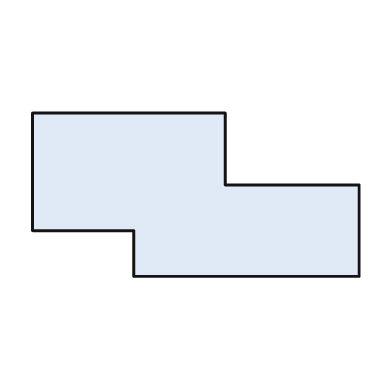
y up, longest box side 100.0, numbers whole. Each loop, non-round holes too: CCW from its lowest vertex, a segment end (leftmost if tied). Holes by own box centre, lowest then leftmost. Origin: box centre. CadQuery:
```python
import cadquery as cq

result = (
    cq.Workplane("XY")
    .moveTo(-19.0, -25.0)
    .lineTo(50.0, -25.0)
    .lineTo(50.0, 3.0)
    .lineTo(9.0, 3.0)
    .lineTo(9.0, 25.0)
    .lineTo(-50.0, 25.0)
    .lineTo(-50.0, -11.0)
    .lineTo(-19.0, -11.0)
    .close()
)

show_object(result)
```